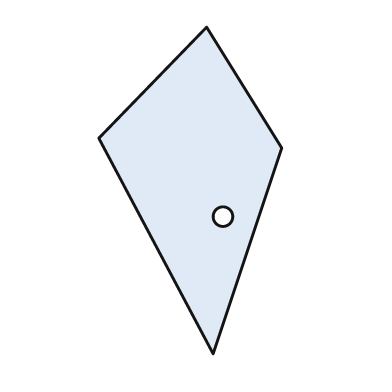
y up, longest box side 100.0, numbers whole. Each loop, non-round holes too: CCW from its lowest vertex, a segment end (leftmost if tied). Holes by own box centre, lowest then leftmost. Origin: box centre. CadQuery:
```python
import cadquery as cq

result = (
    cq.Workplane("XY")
    .moveTo(7.0, -50.0)
    .lineTo(28.0, 13.0)
    .lineTo(5.0, 50.0)
    .lineTo(-28.0, 16.0)
    .close()
    .moveTo(10.0, -8.0)
    .circle(3.0)
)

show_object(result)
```